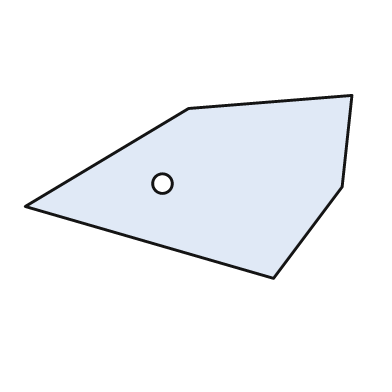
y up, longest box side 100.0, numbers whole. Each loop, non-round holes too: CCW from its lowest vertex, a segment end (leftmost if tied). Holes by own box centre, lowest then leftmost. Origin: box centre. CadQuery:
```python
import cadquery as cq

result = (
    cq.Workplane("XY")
    .moveTo(26.0, -28.0)
    .lineTo(47.0, 0.0)
    .lineTo(50.0, 28.0)
    .lineTo(0.0, 24.0)
    .lineTo(-50.0, -6.0)
    .close()
    .moveTo(-8.0, 1.0)
    .circle(3.0)
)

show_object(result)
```